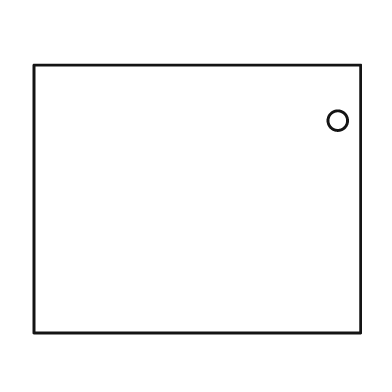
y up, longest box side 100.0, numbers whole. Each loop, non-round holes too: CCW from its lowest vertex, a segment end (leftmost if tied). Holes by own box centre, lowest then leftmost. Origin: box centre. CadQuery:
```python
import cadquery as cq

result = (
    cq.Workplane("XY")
    .moveTo(-50.0, -41.0)
    .lineTo(50.0, -41.0)
    .lineTo(50.0, 41.0)
    .lineTo(-50.0, 41.0)
    .close()
    .moveTo(43.0, 24.0)
    .circle(3.0)
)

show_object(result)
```